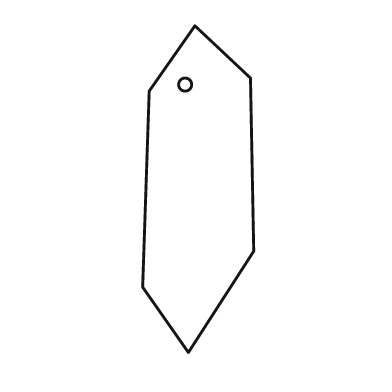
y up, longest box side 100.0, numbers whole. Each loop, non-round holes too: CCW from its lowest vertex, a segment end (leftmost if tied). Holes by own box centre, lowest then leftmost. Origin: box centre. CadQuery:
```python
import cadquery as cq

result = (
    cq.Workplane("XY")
    .moveTo(-3.0, -50.0)
    .lineTo(17.0, -19.0)
    .lineTo(16.0, 34.0)
    .lineTo(-1.0, 50.0)
    .lineTo(-15.0, 30.0)
    .lineTo(-17.0, -30.0)
    .close()
    .moveTo(-4.0, 32.0)
    .circle(2.0)
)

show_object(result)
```